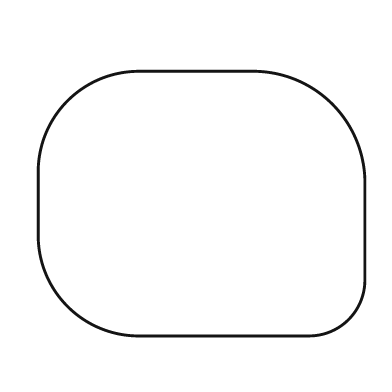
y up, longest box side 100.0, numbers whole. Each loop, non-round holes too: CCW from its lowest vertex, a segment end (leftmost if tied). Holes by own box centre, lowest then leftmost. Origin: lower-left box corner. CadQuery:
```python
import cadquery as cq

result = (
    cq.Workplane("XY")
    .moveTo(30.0, 0.0)
    .lineTo(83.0, 0.0)
    .threePointArc((95.0, 5.0), (100.0, 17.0))
    .lineTo(100.0, 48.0)
    .threePointArc((90.0, 71.0), (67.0, 81.0))
    .lineTo(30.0, 81.0)
    .threePointArc((9.0, 72.0), (0.0, 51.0))
    .lineTo(0.0, 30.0)
    .threePointArc((9.0, 9.0), (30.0, 0.0))
    .close()
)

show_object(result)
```